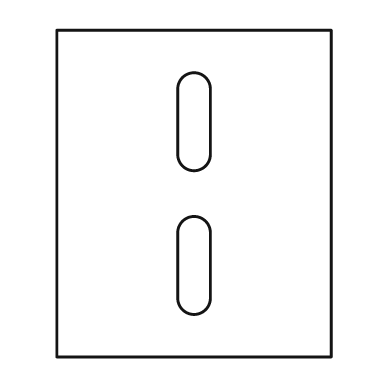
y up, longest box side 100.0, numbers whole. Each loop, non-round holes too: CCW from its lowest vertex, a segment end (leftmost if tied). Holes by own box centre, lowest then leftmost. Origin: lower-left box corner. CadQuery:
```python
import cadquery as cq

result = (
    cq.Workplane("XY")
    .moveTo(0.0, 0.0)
    .lineTo(84.0, 0.0)
    .lineTo(84.0, 100.0)
    .lineTo(0.0, 100.0)
    .close()
    .moveTo(37.0, 18.0)
    .threePointArc((42.0, 13.0), (47.0, 18.0))
    .lineTo(47.0, 38.0)
    .threePointArc((42.0, 43.0), (37.0, 38.0))
    .close()
    .moveTo(37.0, 62.0)
    .threePointArc((42.0, 57.0), (47.0, 62.0))
    .lineTo(47.0, 82.0)
    .threePointArc((42.0, 87.0), (37.0, 82.0))
    .close()
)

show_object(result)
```